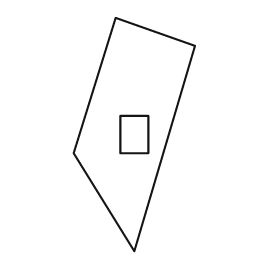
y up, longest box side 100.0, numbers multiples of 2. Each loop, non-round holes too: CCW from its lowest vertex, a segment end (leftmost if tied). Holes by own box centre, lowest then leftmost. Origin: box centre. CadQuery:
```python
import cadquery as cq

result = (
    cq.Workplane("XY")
    .moveTo(0.0, -50.0)
    .lineTo(26.0, 38.0)
    .lineTo(-8.0, 50.0)
    .lineTo(-26.0, -8.0)
    .close()
    .moveTo(-6.0, -8.0)
    .lineTo(6.0, -8.0)
    .lineTo(6.0, 8.0)
    .lineTo(-6.0, 8.0)
    .close()
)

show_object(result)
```